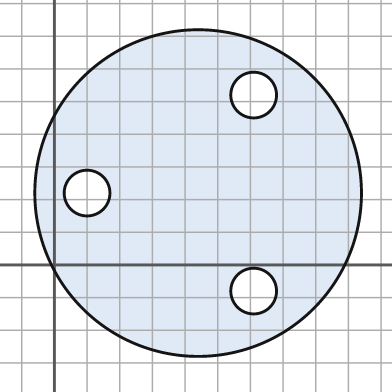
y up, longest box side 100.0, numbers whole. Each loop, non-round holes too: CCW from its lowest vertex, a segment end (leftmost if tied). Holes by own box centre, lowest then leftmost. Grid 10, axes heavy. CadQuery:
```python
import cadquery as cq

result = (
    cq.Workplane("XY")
    .moveTo(44.0, 22.0)
    .circle(50.0)
    .moveTo(61.0, -8.0)
    .circle(7.0)
    .moveTo(10.0, 22.0)
    .circle(7.0)
    .moveTo(61.0, 52.0)
    .circle(7.0)
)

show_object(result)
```